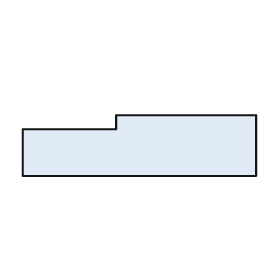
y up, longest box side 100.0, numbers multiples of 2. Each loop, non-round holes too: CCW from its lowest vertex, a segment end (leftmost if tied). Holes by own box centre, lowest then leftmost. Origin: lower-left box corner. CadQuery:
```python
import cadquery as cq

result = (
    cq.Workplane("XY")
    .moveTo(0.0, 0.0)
    .lineTo(100.0, 0.0)
    .lineTo(100.0, 26.0)
    .lineTo(40.0, 26.0)
    .lineTo(40.0, 20.0)
    .lineTo(0.0, 20.0)
    .close()
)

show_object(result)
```